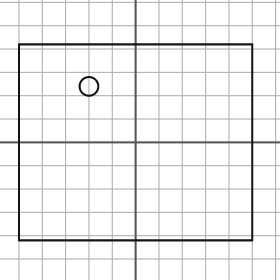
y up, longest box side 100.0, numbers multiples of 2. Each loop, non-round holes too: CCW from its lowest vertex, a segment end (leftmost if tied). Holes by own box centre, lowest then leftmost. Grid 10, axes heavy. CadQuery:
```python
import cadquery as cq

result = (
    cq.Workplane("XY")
    .moveTo(-50.0, -42.0)
    .lineTo(50.0, -42.0)
    .lineTo(50.0, 42.0)
    .lineTo(-50.0, 42.0)
    .close()
    .moveTo(-20.0, 24.0)
    .circle(4.0)
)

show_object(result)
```